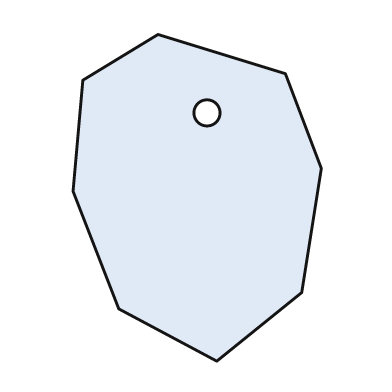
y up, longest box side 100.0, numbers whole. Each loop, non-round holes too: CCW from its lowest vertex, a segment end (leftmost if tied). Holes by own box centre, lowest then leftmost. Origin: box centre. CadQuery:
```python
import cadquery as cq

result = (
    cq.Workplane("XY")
    .moveTo(6.0, -50.0)
    .lineTo(32.0, -29.0)
    .lineTo(38.0, 9.0)
    .lineTo(27.0, 38.0)
    .lineTo(-12.0, 50.0)
    .lineTo(-35.0, 36.0)
    .lineTo(-38.0, 2.0)
    .lineTo(-24.0, -34.0)
    .close()
    .moveTo(3.0, 26.0)
    .circle(4.0)
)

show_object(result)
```